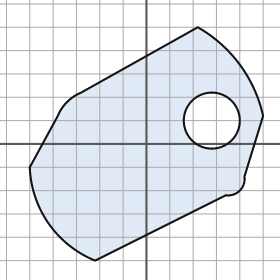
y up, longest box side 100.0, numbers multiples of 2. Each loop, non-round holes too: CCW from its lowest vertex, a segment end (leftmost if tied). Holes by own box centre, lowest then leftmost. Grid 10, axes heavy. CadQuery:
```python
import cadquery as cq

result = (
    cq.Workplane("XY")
    .moveTo(-22.0, -50.0)
    .lineTo(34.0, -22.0)
    .threePointArc((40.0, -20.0), (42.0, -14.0))
    .lineTo(50.0, 12.0)
    .threePointArc((40.0, 34.0), (22.0, 50.0))
    .lineTo(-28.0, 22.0)
    .threePointArc((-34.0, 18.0), (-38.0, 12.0))
    .lineTo(-50.0, -10.0)
    .threePointArc((-42.0, -34.0), (-22.0, -50.0))
    .close()
    .moveTo(28.0, 10.0)
    .circle(12.0)
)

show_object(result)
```